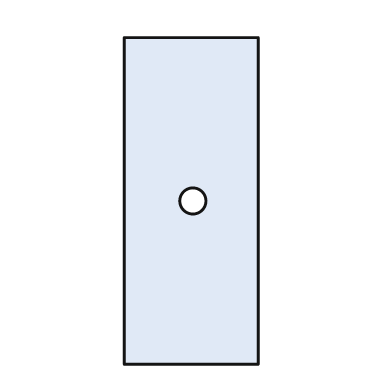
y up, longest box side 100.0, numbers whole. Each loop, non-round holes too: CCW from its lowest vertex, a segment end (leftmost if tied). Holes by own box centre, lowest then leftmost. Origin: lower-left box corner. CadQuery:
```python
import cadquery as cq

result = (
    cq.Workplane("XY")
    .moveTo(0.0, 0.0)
    .lineTo(41.0, 0.0)
    .lineTo(41.0, 100.0)
    .lineTo(0.0, 100.0)
    .close()
    .moveTo(21.0, 50.0)
    .circle(4.0)
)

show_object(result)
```